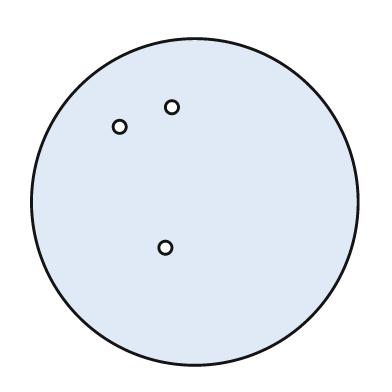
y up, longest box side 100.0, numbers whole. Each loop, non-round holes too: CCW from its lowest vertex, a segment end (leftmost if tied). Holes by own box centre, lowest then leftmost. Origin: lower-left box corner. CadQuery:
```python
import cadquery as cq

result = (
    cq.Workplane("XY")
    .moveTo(50.0, 50.0)
    .circle(50.0)
    .moveTo(41.0, 36.0)
    .circle(2.0)
    .moveTo(27.0, 73.0)
    .circle(2.0)
    .moveTo(43.0, 79.0)
    .circle(2.0)
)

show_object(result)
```